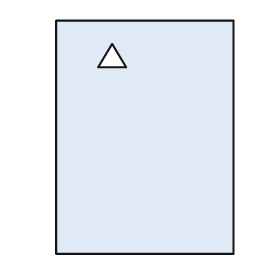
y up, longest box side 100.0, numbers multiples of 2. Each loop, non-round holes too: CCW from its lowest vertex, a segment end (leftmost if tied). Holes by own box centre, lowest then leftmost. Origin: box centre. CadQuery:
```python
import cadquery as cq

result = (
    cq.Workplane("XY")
    .moveTo(-38.0, -50.0)
    .lineTo(38.0, -50.0)
    .lineTo(38.0, 50.0)
    .lineTo(-38.0, 50.0)
    .close()
    .moveTo(-20.0, 30.0)
    .lineTo(-8.0, 30.0)
    .lineTo(-14.0, 40.0)
    .close()
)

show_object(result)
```